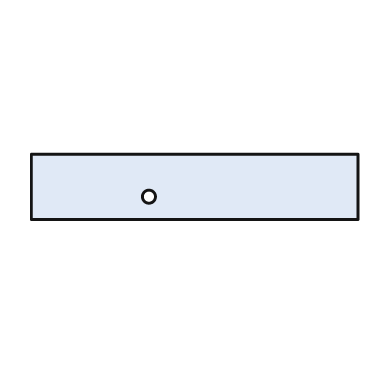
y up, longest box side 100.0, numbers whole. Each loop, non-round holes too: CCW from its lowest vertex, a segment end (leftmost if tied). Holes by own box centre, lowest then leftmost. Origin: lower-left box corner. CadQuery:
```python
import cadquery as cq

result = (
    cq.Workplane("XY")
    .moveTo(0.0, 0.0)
    .lineTo(100.0, 0.0)
    .lineTo(100.0, 20.0)
    .lineTo(0.0, 20.0)
    .close()
    .moveTo(36.0, 7.0)
    .circle(2.0)
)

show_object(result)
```